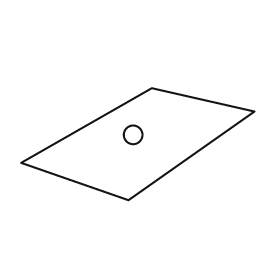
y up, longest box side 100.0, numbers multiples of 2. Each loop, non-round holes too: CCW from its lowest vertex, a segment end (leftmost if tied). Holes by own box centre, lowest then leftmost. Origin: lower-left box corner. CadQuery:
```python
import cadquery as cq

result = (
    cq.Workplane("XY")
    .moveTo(46.0, 0.0)
    .lineTo(100.0, 38.0)
    .lineTo(56.0, 48.0)
    .lineTo(0.0, 16.0)
    .close()
    .moveTo(48.0, 28.0)
    .circle(4.0)
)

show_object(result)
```